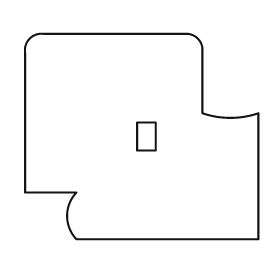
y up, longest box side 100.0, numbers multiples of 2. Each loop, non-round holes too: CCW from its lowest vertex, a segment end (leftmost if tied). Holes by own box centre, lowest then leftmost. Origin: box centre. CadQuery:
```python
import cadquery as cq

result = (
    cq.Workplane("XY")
    .moveTo(-28.0, -44.0)
    .lineTo(50.0, -44.0)
    .lineTo(50.0, 10.0)
    .threePointArc((38.0, 8.0), (26.0, 10.0))
    .lineTo(26.0, 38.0)
    .threePointArc((24.0, 42.0), (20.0, 44.0))
    .lineTo(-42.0, 44.0)
    .threePointArc((-48.0, 42.0), (-50.0, 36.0))
    .lineTo(-50.0, -24.0)
    .lineTo(-28.0, -24.0)
    .threePointArc((-32.0, -34.0), (-28.0, -44.0))
    .close()
    .moveTo(-2.0, -6.0)
    .lineTo(6.0, -6.0)
    .lineTo(6.0, 6.0)
    .lineTo(-2.0, 6.0)
    .close()
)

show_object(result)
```